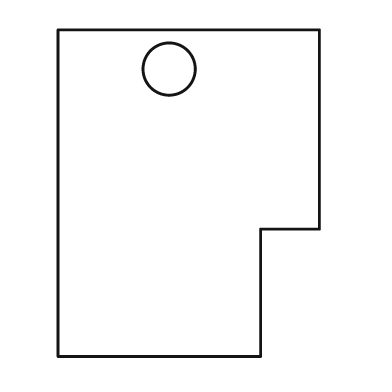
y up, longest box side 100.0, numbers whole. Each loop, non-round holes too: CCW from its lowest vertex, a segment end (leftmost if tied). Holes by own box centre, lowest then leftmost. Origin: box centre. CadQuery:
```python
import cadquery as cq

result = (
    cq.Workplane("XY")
    .moveTo(-40.0, -50.0)
    .lineTo(22.0, -50.0)
    .lineTo(22.0, -11.0)
    .lineTo(40.0, -11.0)
    .lineTo(40.0, 50.0)
    .lineTo(-40.0, 50.0)
    .close()
    .moveTo(-6.0, 38.0)
    .circle(8.0)
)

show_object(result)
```